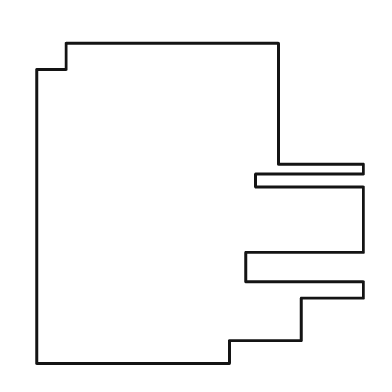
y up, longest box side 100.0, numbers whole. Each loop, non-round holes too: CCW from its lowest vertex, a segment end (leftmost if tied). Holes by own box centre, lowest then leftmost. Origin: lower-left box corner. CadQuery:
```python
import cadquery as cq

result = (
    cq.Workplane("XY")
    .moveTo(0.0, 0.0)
    .lineTo(59.0, 0.0)
    .lineTo(59.0, 7.0)
    .lineTo(81.0, 7.0)
    .lineTo(81.0, 20.0)
    .lineTo(100.0, 20.0)
    .lineTo(100.0, 25.0)
    .lineTo(64.0, 25.0)
    .lineTo(64.0, 34.0)
    .lineTo(100.0, 34.0)
    .lineTo(100.0, 54.0)
    .lineTo(67.0, 54.0)
    .lineTo(67.0, 58.0)
    .lineTo(100.0, 58.0)
    .lineTo(100.0, 61.0)
    .lineTo(74.0, 61.0)
    .lineTo(74.0, 98.0)
    .lineTo(9.0, 98.0)
    .lineTo(9.0, 90.0)
    .lineTo(0.0, 90.0)
    .close()
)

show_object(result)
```